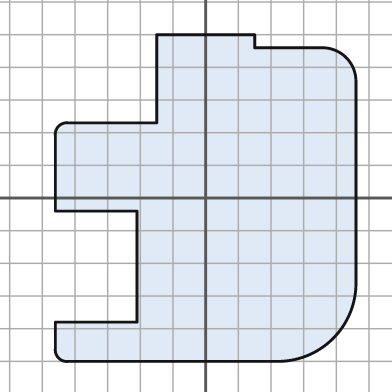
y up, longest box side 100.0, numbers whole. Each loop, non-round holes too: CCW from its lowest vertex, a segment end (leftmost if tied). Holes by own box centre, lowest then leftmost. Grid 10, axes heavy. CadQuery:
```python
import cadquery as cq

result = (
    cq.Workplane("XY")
    .moveTo(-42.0, -50.0)
    .lineTo(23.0, -50.0)
    .threePointArc((39.0, -43.0), (46.0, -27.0))
    .lineTo(46.0, 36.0)
    .threePointArc((43.0, 43.0), (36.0, 46.0))
    .lineTo(15.0, 46.0)
    .lineTo(15.0, 50.0)
    .lineTo(-15.0, 50.0)
    .lineTo(-15.0, 23.0)
    .lineTo(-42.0, 23.0)
    .threePointArc((-45.0, 22.0), (-46.0, 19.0))
    .lineTo(-46.0, -4.0)
    .lineTo(-21.0, -4.0)
    .lineTo(-21.0, -38.0)
    .lineTo(-46.0, -38.0)
    .lineTo(-46.0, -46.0)
    .threePointArc((-45.0, -49.0), (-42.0, -50.0))
    .close()
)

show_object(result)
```